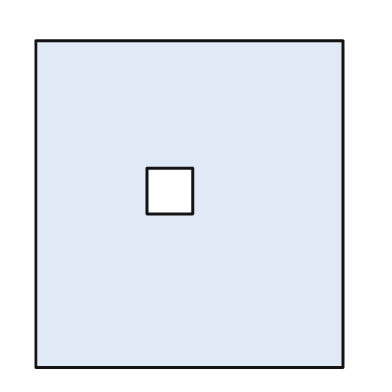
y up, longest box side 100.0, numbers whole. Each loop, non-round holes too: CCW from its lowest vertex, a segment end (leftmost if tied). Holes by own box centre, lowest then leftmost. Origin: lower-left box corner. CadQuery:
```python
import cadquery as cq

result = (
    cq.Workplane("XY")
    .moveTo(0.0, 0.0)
    .lineTo(94.0, 0.0)
    .lineTo(94.0, 100.0)
    .lineTo(0.0, 100.0)
    .close()
    .moveTo(34.0, 47.0)
    .lineTo(48.0, 47.0)
    .lineTo(48.0, 61.0)
    .lineTo(34.0, 61.0)
    .close()
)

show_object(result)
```